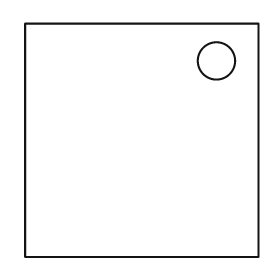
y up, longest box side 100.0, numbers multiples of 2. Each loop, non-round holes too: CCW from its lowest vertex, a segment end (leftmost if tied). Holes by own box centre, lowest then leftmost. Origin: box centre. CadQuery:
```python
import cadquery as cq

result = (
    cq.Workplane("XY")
    .moveTo(-50.0, -50.0)
    .lineTo(50.0, -50.0)
    .lineTo(50.0, 50.0)
    .lineTo(-50.0, 50.0)
    .close()
    .moveTo(32.0, 34.0)
    .circle(8.0)
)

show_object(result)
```